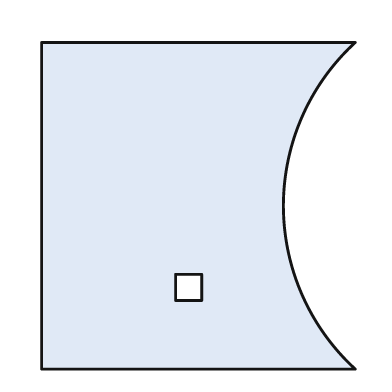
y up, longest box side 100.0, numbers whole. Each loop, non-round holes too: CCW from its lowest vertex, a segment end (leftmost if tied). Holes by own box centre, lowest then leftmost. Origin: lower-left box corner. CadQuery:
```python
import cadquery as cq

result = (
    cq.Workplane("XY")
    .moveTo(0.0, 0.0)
    .lineTo(96.0, 0.0)
    .threePointArc((74.0, 50.0), (96.0, 100.0))
    .lineTo(0.0, 100.0)
    .close()
    .moveTo(41.0, 21.0)
    .lineTo(49.0, 21.0)
    .lineTo(49.0, 29.0)
    .lineTo(41.0, 29.0)
    .close()
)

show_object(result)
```